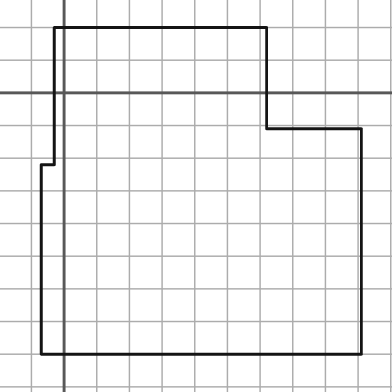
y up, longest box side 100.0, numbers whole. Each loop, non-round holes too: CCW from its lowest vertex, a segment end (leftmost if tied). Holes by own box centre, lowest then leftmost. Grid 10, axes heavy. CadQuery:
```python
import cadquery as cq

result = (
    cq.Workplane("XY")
    .moveTo(-7.0, -80.0)
    .lineTo(91.0, -80.0)
    .lineTo(91.0, -11.0)
    .lineTo(62.0, -11.0)
    .lineTo(62.0, 20.0)
    .lineTo(-3.0, 20.0)
    .lineTo(-3.0, -22.0)
    .lineTo(-7.0, -22.0)
    .close()
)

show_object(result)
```